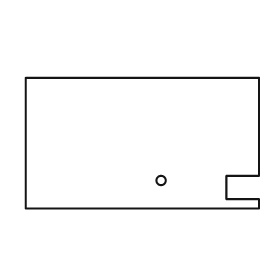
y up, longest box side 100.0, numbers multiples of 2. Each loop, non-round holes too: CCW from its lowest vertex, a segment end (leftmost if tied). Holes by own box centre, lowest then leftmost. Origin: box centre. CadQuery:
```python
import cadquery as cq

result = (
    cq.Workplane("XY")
    .moveTo(-50.0, -28.0)
    .lineTo(50.0, -28.0)
    .lineTo(50.0, -24.0)
    .lineTo(36.0, -24.0)
    .lineTo(36.0, -14.0)
    .lineTo(50.0, -14.0)
    .lineTo(50.0, 28.0)
    .lineTo(-50.0, 28.0)
    .close()
    .moveTo(8.0, -16.0)
    .circle(2.0)
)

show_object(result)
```